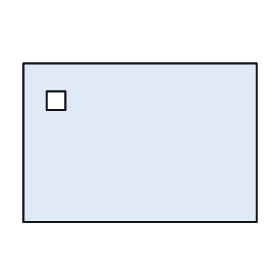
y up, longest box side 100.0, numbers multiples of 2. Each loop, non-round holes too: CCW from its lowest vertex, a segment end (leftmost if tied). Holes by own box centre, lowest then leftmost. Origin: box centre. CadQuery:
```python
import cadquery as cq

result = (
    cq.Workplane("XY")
    .moveTo(-50.0, -34.0)
    .lineTo(50.0, -34.0)
    .lineTo(50.0, 34.0)
    .lineTo(-50.0, 34.0)
    .close()
    .moveTo(-40.0, 14.0)
    .lineTo(-32.0, 14.0)
    .lineTo(-32.0, 22.0)
    .lineTo(-40.0, 22.0)
    .close()
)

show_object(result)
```